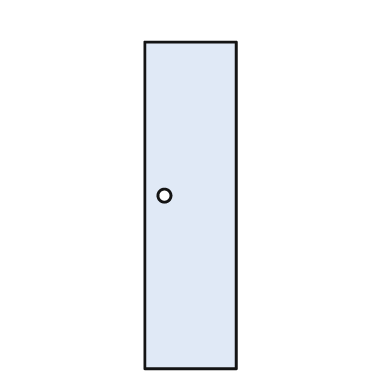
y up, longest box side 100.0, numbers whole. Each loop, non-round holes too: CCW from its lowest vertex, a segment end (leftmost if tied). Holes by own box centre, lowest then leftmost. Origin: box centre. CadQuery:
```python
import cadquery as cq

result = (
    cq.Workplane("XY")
    .moveTo(-14.0, -50.0)
    .lineTo(14.0, -50.0)
    .lineTo(14.0, 50.0)
    .lineTo(-14.0, 50.0)
    .close()
    .moveTo(-8.0, 3.0)
    .circle(2.0)
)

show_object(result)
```